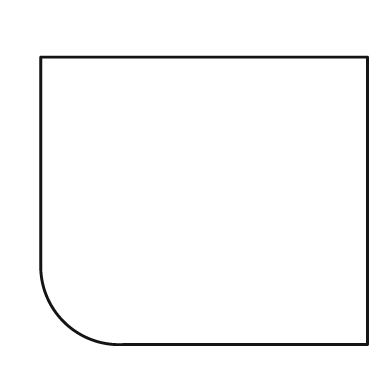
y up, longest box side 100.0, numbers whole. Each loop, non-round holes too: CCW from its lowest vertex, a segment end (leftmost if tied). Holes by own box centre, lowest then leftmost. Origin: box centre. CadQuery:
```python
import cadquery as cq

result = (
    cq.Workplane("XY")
    .moveTo(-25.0, -44.0)
    .lineTo(50.0, -44.0)
    .lineTo(50.0, 44.0)
    .lineTo(-50.0, 44.0)
    .lineTo(-50.0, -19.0)
    .threePointArc((-43.0, -37.0), (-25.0, -44.0))
    .close()
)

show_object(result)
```